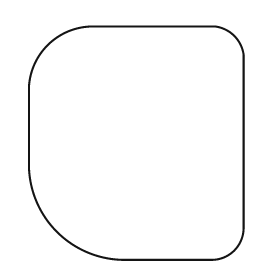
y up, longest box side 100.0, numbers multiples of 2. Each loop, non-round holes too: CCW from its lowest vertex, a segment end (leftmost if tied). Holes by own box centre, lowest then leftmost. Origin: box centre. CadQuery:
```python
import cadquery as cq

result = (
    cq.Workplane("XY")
    .moveTo(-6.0, -50.0)
    .lineTo(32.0, -50.0)
    .threePointArc((42.0, -46.0), (46.0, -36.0))
    .lineTo(46.0, 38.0)
    .threePointArc((42.0, 46.0), (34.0, 50.0))
    .lineTo(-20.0, 50.0)
    .threePointArc((-38.0, 42.0), (-46.0, 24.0))
    .lineTo(-46.0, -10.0)
    .threePointArc((-34.0, -38.0), (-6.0, -50.0))
    .close()
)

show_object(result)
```